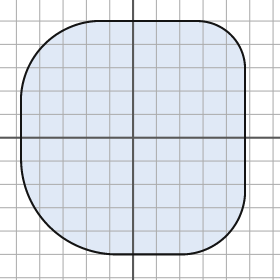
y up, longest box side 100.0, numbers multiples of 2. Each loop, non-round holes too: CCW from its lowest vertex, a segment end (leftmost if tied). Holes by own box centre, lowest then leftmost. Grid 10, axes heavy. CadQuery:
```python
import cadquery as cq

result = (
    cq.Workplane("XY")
    .moveTo(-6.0, -50.0)
    .lineTo(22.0, -50.0)
    .threePointArc((40.0, -42.0), (48.0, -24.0))
    .lineTo(48.0, 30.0)
    .threePointArc((42.0, 44.0), (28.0, 50.0))
    .lineTo(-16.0, 50.0)
    .threePointArc((-38.0, 40.0), (-48.0, 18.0))
    .lineTo(-48.0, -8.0)
    .threePointArc((-36.0, -38.0), (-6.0, -50.0))
    .close()
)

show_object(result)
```